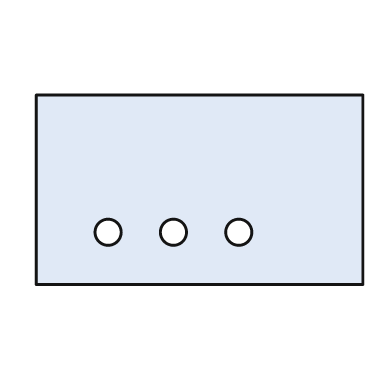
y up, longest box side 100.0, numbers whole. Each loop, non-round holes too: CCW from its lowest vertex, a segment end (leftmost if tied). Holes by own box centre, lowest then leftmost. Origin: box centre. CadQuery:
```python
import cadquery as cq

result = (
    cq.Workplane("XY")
    .moveTo(-50.0, -29.0)
    .lineTo(50.0, -29.0)
    .lineTo(50.0, 29.0)
    .lineTo(-50.0, 29.0)
    .close()
    .moveTo(-28.0, -13.0)
    .circle(4.0)
    .moveTo(-8.0, -13.0)
    .circle(4.0)
    .moveTo(12.0, -13.0)
    .circle(4.0)
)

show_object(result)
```